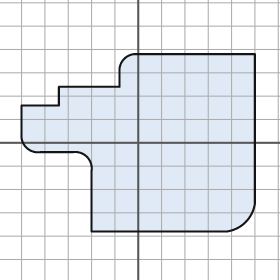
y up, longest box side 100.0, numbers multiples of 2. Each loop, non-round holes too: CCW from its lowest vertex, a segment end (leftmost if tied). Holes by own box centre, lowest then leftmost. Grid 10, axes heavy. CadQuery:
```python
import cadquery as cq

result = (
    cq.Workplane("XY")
    .moveTo(-20.0, -38.0)
    .lineTo(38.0, -38.0)
    .threePointArc((46.0, -34.0), (50.0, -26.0))
    .lineTo(50.0, 38.0)
    .lineTo(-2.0, 38.0)
    .threePointArc((-6.0, 36.0), (-8.0, 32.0))
    .lineTo(-8.0, 24.0)
    .lineTo(-34.0, 24.0)
    .lineTo(-34.0, 16.0)
    .lineTo(-50.0, 16.0)
    .lineTo(-50.0, 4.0)
    .threePointArc((-48.0, -2.0), (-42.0, -4.0))
    .lineTo(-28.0, -4.0)
    .threePointArc((-22.0, -6.0), (-20.0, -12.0))
    .close()
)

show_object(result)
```